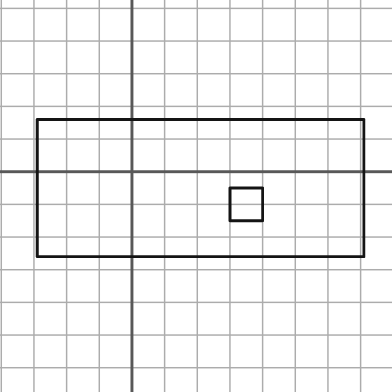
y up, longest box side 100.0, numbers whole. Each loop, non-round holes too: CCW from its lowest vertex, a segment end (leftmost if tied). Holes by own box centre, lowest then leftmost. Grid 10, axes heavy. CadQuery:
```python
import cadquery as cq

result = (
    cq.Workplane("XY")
    .moveTo(-29.0, -26.0)
    .lineTo(71.0, -26.0)
    .lineTo(71.0, 16.0)
    .lineTo(-29.0, 16.0)
    .close()
    .moveTo(30.0, -15.0)
    .lineTo(40.0, -15.0)
    .lineTo(40.0, -5.0)
    .lineTo(30.0, -5.0)
    .close()
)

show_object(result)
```